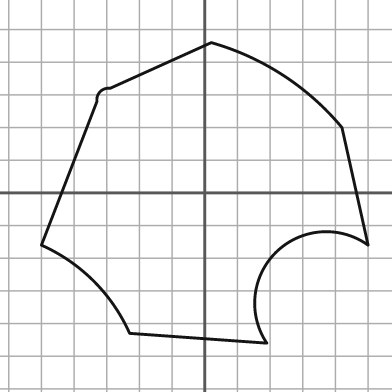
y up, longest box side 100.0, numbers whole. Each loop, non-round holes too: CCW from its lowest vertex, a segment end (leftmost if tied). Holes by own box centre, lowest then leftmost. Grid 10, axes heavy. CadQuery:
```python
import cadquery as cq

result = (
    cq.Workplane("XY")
    .moveTo(19.0, -46.0)
    .threePointArc((22.0, -18.0), (50.0, -16.0))
    .lineTo(42.0, 20.0)
    .threePointArc((24.0, 36.0), (2.0, 46.0))
    .lineTo(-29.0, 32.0)
    .threePointArc((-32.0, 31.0), (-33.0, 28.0))
    .lineTo(-50.0, -16.0)
    .threePointArc((-34.0, -27.0), (-23.0, -43.0))
    .close()
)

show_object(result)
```